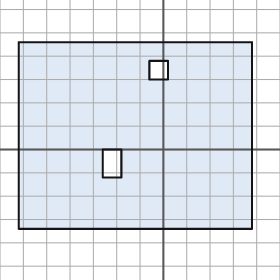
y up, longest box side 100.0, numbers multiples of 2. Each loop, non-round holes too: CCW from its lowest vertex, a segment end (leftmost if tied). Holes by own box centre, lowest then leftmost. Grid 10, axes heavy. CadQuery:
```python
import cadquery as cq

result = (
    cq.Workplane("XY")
    .moveTo(-62.0, -34.0)
    .lineTo(38.0, -34.0)
    .lineTo(38.0, 46.0)
    .lineTo(-62.0, 46.0)
    .close()
    .moveTo(-26.0, -12.0)
    .lineTo(-18.0, -12.0)
    .lineTo(-18.0, 0.0)
    .lineTo(-26.0, 0.0)
    .close()
    .moveTo(-6.0, 30.0)
    .lineTo(2.0, 30.0)
    .lineTo(2.0, 38.0)
    .lineTo(-6.0, 38.0)
    .close()
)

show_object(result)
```